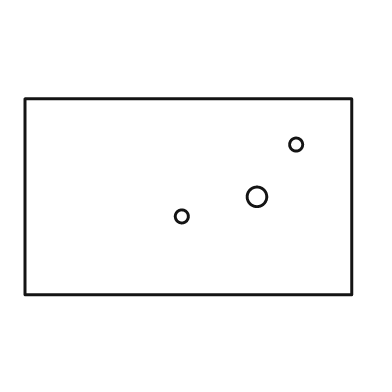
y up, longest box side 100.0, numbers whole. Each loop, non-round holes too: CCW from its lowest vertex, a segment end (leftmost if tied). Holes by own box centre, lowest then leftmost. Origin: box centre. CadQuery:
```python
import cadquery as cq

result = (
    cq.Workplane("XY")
    .moveTo(-50.0, -30.0)
    .lineTo(50.0, -30.0)
    .lineTo(50.0, 30.0)
    .lineTo(-50.0, 30.0)
    .close()
    .moveTo(-2.0, -6.0)
    .circle(2.0)
    .moveTo(21.0, 0.0)
    .circle(3.0)
    .moveTo(33.0, 16.0)
    .circle(2.0)
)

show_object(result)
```